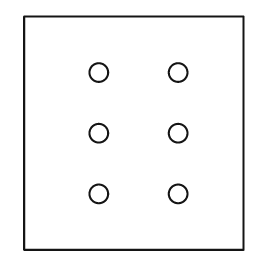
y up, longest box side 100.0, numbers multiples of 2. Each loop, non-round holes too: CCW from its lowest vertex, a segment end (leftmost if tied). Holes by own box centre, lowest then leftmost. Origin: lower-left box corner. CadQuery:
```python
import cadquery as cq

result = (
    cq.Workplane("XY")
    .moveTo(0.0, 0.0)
    .lineTo(94.0, 0.0)
    .lineTo(94.0, 100.0)
    .lineTo(0.0, 100.0)
    .close()
    .moveTo(32.0, 24.0)
    .circle(4.0)
    .moveTo(66.0, 24.0)
    .circle(4.0)
    .moveTo(32.0, 50.0)
    .circle(4.0)
    .moveTo(66.0, 50.0)
    .circle(4.0)
    .moveTo(32.0, 76.0)
    .circle(4.0)
    .moveTo(66.0, 76.0)
    .circle(4.0)
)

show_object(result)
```